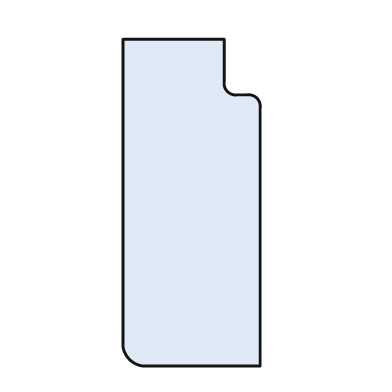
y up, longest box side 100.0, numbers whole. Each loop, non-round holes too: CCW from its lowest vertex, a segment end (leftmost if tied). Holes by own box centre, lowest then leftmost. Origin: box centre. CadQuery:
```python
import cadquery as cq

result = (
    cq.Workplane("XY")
    .moveTo(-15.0, -50.0)
    .lineTo(21.0, -50.0)
    .lineTo(21.0, 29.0)
    .threePointArc((20.0, 32.0), (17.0, 33.0))
    .lineTo(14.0, 33.0)
    .threePointArc((11.0, 34.0), (10.0, 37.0))
    .lineTo(10.0, 50.0)
    .lineTo(-21.0, 50.0)
    .lineTo(-21.0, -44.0)
    .threePointArc((-19.0, -48.0), (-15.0, -50.0))
    .close()
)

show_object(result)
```